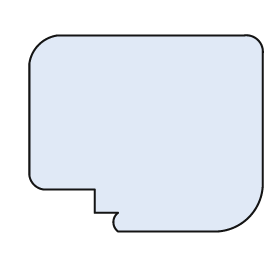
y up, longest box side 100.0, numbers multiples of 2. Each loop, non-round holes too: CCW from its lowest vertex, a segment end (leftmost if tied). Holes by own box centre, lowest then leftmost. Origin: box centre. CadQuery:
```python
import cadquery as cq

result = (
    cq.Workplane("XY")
    .moveTo(-12.0, -42.0)
    .lineTo(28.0, -42.0)
    .threePointArc((44.0, -36.0), (50.0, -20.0))
    .lineTo(50.0, 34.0)
    .threePointArc((48.0, 40.0), (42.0, 42.0))
    .lineTo(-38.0, 42.0)
    .threePointArc((-46.0, 38.0), (-50.0, 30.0))
    .lineTo(-50.0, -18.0)
    .threePointArc((-48.0, -22.0), (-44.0, -24.0))
    .lineTo(-22.0, -24.0)
    .lineTo(-22.0, -34.0)
    .lineTo(-12.0, -34.0)
    .threePointArc((-14.0, -38.0), (-12.0, -42.0))
    .close()
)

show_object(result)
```